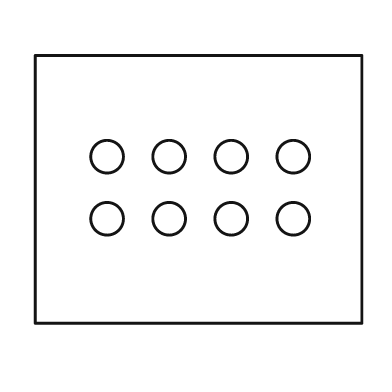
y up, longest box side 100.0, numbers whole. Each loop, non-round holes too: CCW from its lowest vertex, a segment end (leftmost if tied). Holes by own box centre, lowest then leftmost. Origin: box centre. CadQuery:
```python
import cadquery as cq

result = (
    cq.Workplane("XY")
    .moveTo(-50.0, -41.0)
    .lineTo(50.0, -41.0)
    .lineTo(50.0, 41.0)
    .lineTo(-50.0, 41.0)
    .close()
    .moveTo(-28.0, -9.0)
    .circle(5.0)
    .moveTo(-9.0, -9.0)
    .circle(5.0)
    .moveTo(10.0, -9.0)
    .circle(5.0)
    .moveTo(29.0, -9.0)
    .circle(5.0)
    .moveTo(-28.0, 10.0)
    .circle(5.0)
    .moveTo(-9.0, 10.0)
    .circle(5.0)
    .moveTo(10.0, 10.0)
    .circle(5.0)
    .moveTo(29.0, 10.0)
    .circle(5.0)
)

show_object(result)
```